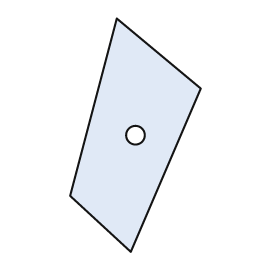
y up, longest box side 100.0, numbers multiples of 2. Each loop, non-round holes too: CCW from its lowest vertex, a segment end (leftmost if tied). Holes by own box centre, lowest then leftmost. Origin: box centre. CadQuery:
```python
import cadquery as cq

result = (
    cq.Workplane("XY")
    .moveTo(-2.0, -50.0)
    .lineTo(28.0, 20.0)
    .lineTo(-8.0, 50.0)
    .lineTo(-28.0, -26.0)
    .close()
    .moveTo(0.0, 0.0)
    .circle(4.0)
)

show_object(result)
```